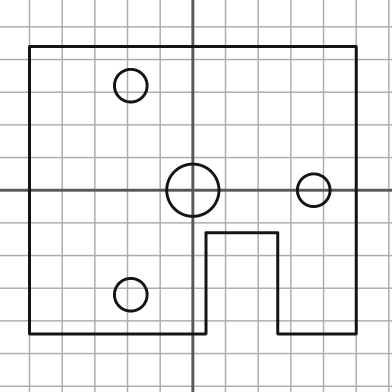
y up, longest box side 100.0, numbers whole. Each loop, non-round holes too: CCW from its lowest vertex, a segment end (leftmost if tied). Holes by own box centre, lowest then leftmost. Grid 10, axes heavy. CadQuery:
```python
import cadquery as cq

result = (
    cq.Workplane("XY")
    .moveTo(-50.0, -44.0)
    .lineTo(4.0, -44.0)
    .lineTo(4.0, -13.0)
    .lineTo(26.0, -13.0)
    .lineTo(26.0, -44.0)
    .lineTo(50.0, -44.0)
    .lineTo(50.0, 44.0)
    .lineTo(-50.0, 44.0)
    .close()
    .moveTo(-19.0, -32.0)
    .circle(5.0)
    .moveTo(0.0, 0.0)
    .circle(8.0)
    .moveTo(37.0, 0.0)
    .circle(5.0)
    .moveTo(-19.0, 32.0)
    .circle(5.0)
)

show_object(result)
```